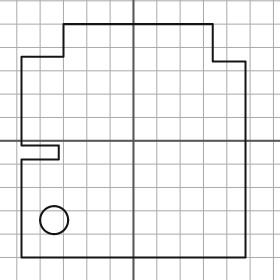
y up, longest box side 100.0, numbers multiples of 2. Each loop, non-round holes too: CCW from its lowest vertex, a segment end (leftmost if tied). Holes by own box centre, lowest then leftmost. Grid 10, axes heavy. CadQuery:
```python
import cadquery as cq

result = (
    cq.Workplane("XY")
    .moveTo(-48.0, -50.0)
    .lineTo(48.0, -50.0)
    .lineTo(48.0, 34.0)
    .lineTo(34.0, 34.0)
    .lineTo(34.0, 50.0)
    .lineTo(-30.0, 50.0)
    .lineTo(-30.0, 36.0)
    .lineTo(-48.0, 36.0)
    .lineTo(-48.0, -2.0)
    .lineTo(-32.0, -2.0)
    .lineTo(-32.0, -8.0)
    .lineTo(-48.0, -8.0)
    .close()
    .moveTo(-34.0, -34.0)
    .circle(6.0)
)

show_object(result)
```